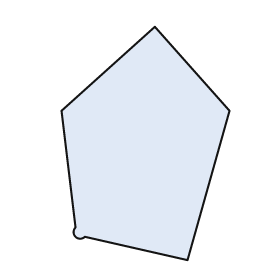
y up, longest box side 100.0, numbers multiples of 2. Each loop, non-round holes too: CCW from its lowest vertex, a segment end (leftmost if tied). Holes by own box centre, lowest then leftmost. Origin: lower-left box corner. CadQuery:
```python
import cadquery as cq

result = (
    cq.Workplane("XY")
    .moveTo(54.0, 0.0)
    .lineTo(72.0, 64.0)
    .lineTo(40.0, 100.0)
    .lineTo(0.0, 64.0)
    .lineTo(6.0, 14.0)
    .threePointArc((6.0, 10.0), (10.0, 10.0))
    .close()
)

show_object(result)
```